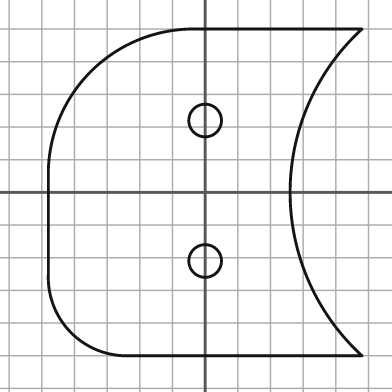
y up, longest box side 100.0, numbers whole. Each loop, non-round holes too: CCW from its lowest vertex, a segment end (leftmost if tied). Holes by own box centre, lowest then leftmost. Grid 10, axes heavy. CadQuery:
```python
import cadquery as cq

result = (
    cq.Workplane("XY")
    .moveTo(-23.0, -50.0)
    .lineTo(48.0, -50.0)
    .threePointArc((26.0, 0.0), (48.0, 50.0))
    .lineTo(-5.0, 50.0)
    .threePointArc((-35.0, 37.0), (-48.0, 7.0))
    .lineTo(-48.0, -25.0)
    .threePointArc((-41.0, -43.0), (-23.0, -50.0))
    .close()
    .moveTo(0.0, -21.0)
    .circle(5.0)
    .moveTo(0.0, 22.0)
    .circle(5.0)
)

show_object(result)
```